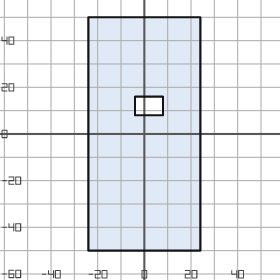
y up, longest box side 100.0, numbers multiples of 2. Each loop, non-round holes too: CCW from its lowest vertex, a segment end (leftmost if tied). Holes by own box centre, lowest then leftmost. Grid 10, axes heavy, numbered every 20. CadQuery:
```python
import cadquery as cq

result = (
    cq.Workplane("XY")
    .moveTo(-24.0, -50.0)
    .lineTo(24.0, -50.0)
    .lineTo(24.0, 50.0)
    .lineTo(-24.0, 50.0)
    .close()
    .moveTo(-4.0, 8.0)
    .lineTo(8.0, 8.0)
    .lineTo(8.0, 16.0)
    .lineTo(-4.0, 16.0)
    .close()
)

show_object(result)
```